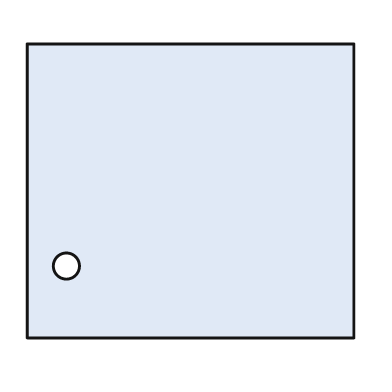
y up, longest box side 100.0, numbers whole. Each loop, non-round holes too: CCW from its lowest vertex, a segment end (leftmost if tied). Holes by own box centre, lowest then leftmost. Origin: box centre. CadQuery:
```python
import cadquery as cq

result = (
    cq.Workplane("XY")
    .moveTo(-50.0, -45.0)
    .lineTo(50.0, -45.0)
    .lineTo(50.0, 45.0)
    .lineTo(-50.0, 45.0)
    .close()
    .moveTo(-38.0, -23.0)
    .circle(4.0)
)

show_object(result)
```